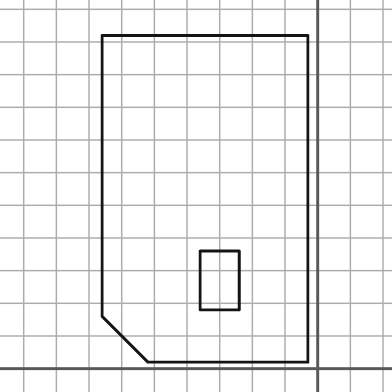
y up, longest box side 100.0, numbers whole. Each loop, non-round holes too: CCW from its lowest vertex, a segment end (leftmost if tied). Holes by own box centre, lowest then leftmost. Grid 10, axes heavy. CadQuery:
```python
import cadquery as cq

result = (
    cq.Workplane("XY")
    .moveTo(-52.0, 2.0)
    .lineTo(-3.0, 2.0)
    .lineTo(-3.0, 102.0)
    .lineTo(-66.0, 102.0)
    .lineTo(-66.0, 16.0)
    .close()
    .moveTo(-36.0, 18.0)
    .lineTo(-24.0, 18.0)
    .lineTo(-24.0, 36.0)
    .lineTo(-36.0, 36.0)
    .close()
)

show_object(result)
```